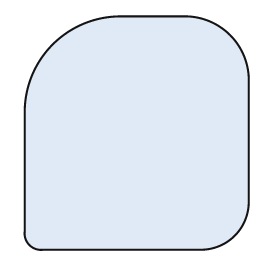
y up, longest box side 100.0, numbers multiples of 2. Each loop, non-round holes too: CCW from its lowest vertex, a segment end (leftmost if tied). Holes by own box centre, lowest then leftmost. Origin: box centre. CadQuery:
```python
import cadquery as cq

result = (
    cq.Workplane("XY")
    .moveTo(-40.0, -50.0)
    .lineTo(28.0, -50.0)
    .threePointArc((42.0, -44.0), (48.0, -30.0))
    .lineTo(48.0, 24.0)
    .threePointArc((40.0, 42.0), (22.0, 50.0))
    .lineTo(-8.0, 50.0)
    .threePointArc((-36.0, 38.0), (-48.0, 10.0))
    .lineTo(-48.0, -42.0)
    .threePointArc((-46.0, -48.0), (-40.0, -50.0))
    .close()
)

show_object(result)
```